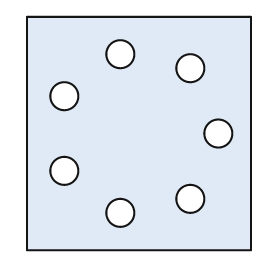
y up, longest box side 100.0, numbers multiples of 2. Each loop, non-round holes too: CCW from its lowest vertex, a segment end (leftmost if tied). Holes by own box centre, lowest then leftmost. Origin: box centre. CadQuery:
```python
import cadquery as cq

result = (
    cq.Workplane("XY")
    .moveTo(-48.0, -50.0)
    .lineTo(48.0, -50.0)
    .lineTo(48.0, 50.0)
    .lineTo(-48.0, 50.0)
    .close()
    .moveTo(-8.0, -34.0)
    .circle(6.0)
    .moveTo(22.0, -28.0)
    .circle(6.0)
    .moveTo(-32.0, -16.0)
    .circle(6.0)
    .moveTo(34.0, 0.0)
    .circle(6.0)
    .moveTo(-32.0, 16.0)
    .circle(6.0)
    .moveTo(22.0, 28.0)
    .circle(6.0)
    .moveTo(-8.0, 34.0)
    .circle(6.0)
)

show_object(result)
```